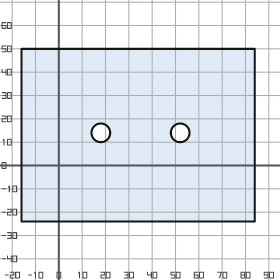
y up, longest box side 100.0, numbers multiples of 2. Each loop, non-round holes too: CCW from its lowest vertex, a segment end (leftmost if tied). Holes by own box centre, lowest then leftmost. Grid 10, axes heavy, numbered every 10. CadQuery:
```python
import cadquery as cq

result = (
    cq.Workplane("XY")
    .moveTo(-16.0, -24.0)
    .lineTo(84.0, -24.0)
    .lineTo(84.0, 50.0)
    .lineTo(-16.0, 50.0)
    .close()
    .moveTo(18.0, 14.0)
    .circle(4.0)
    .moveTo(52.0, 14.0)
    .circle(4.0)
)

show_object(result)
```